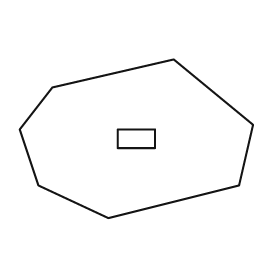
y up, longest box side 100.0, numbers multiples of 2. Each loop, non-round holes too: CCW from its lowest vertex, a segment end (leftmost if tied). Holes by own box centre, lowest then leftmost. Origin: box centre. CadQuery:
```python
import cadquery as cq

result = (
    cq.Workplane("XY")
    .moveTo(-12.0, -34.0)
    .lineTo(44.0, -20.0)
    .lineTo(50.0, 6.0)
    .lineTo(16.0, 34.0)
    .lineTo(-36.0, 22.0)
    .lineTo(-50.0, 4.0)
    .lineTo(-42.0, -20.0)
    .close()
    .moveTo(-8.0, -4.0)
    .lineTo(8.0, -4.0)
    .lineTo(8.0, 4.0)
    .lineTo(-8.0, 4.0)
    .close()
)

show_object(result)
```